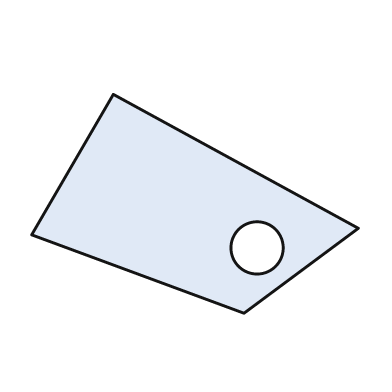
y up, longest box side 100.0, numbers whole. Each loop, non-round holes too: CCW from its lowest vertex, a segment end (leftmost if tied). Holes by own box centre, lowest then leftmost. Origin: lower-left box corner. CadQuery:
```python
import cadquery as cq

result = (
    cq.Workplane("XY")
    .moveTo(65.0, 0.0)
    .lineTo(100.0, 26.0)
    .lineTo(25.0, 67.0)
    .lineTo(0.0, 24.0)
    .close()
    .moveTo(69.0, 20.0)
    .circle(8.0)
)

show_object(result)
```